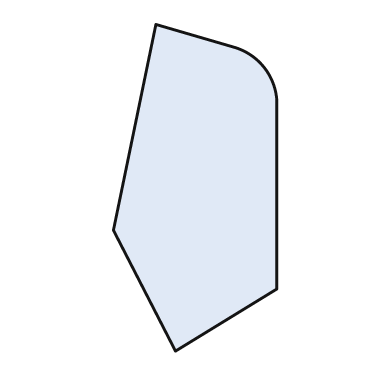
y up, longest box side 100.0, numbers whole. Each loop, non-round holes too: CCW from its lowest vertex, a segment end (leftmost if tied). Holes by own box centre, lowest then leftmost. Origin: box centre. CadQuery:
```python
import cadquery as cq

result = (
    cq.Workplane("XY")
    .moveTo(-6.0, -50.0)
    .lineTo(25.0, -31.0)
    .lineTo(25.0, 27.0)
    .threePointArc((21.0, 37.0), (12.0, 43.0))
    .lineTo(-12.0, 50.0)
    .lineTo(-25.0, -13.0)
    .close()
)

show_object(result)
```